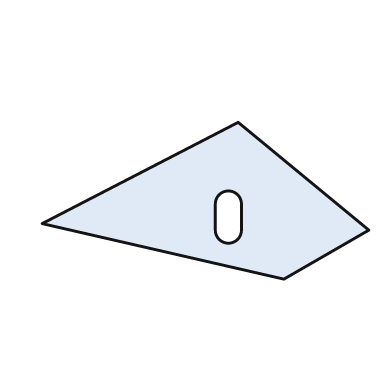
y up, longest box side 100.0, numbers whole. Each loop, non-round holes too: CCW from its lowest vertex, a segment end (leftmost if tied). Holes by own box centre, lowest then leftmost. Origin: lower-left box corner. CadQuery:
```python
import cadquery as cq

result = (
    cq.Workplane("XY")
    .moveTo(74.0, 0.0)
    .lineTo(100.0, 15.0)
    .lineTo(60.0, 48.0)
    .lineTo(0.0, 17.0)
    .close()
    .moveTo(53.0, 15.0)
    .threePointArc((57.0, 11.0), (61.0, 15.0))
    .lineTo(61.0, 23.0)
    .threePointArc((57.0, 27.0), (53.0, 23.0))
    .close()
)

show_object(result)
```